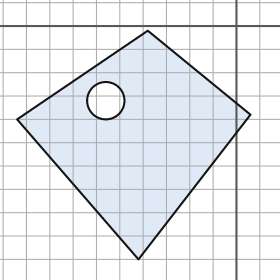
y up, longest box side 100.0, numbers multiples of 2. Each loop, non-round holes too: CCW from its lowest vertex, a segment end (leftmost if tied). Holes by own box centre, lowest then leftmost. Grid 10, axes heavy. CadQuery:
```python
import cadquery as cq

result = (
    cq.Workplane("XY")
    .moveTo(-42.0, -100.0)
    .lineTo(6.0, -38.0)
    .lineTo(-38.0, -2.0)
    .lineTo(-94.0, -40.0)
    .close()
    .moveTo(-56.0, -32.0)
    .circle(8.0)
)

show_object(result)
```